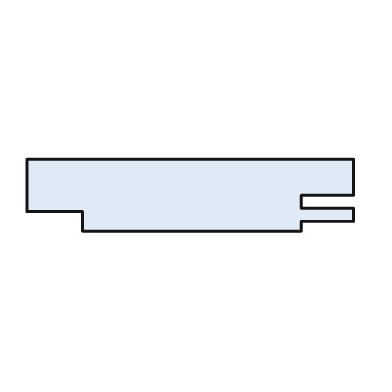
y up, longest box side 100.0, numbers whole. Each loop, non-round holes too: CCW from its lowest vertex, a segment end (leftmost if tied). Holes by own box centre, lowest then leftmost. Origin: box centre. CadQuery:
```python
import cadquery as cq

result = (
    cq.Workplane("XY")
    .moveTo(-33.0, -11.0)
    .lineTo(34.0, -11.0)
    .lineTo(34.0, -8.0)
    .lineTo(50.0, -8.0)
    .lineTo(50.0, -4.0)
    .lineTo(34.0, -4.0)
    .lineTo(34.0, 0.0)
    .lineTo(50.0, 0.0)
    .lineTo(50.0, 11.0)
    .lineTo(-50.0, 11.0)
    .lineTo(-50.0, -5.0)
    .lineTo(-33.0, -5.0)
    .close()
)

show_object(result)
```